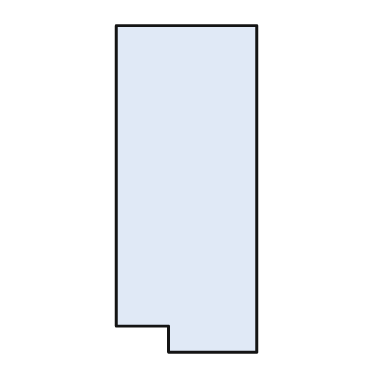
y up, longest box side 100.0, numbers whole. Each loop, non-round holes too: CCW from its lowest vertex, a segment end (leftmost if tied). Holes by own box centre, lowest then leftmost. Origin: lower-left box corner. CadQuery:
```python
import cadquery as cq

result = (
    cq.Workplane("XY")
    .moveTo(16.0, 0.0)
    .lineTo(43.0, 0.0)
    .lineTo(43.0, 100.0)
    .lineTo(0.0, 100.0)
    .lineTo(0.0, 8.0)
    .lineTo(16.0, 8.0)
    .close()
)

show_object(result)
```